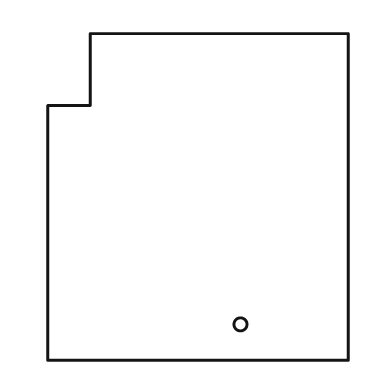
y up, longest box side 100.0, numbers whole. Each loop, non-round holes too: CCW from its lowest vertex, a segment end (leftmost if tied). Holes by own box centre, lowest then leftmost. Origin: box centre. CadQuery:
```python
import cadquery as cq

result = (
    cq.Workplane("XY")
    .moveTo(-46.0, -50.0)
    .lineTo(46.0, -50.0)
    .lineTo(46.0, 50.0)
    .lineTo(-33.0, 50.0)
    .lineTo(-33.0, 28.0)
    .lineTo(-46.0, 28.0)
    .close()
    .moveTo(13.0, -39.0)
    .circle(2.0)
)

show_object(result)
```